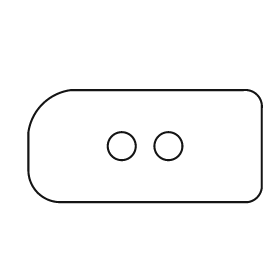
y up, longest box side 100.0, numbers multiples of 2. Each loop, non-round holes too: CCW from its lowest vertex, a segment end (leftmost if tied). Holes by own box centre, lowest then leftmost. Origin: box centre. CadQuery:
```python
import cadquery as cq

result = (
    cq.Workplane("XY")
    .moveTo(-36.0, -24.0)
    .lineTo(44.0, -24.0)
    .threePointArc((48.0, -22.0), (50.0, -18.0))
    .lineTo(50.0, 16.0)
    .threePointArc((48.0, 22.0), (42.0, 24.0))
    .lineTo(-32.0, 24.0)
    .threePointArc((-44.0, 18.0), (-50.0, 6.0))
    .lineTo(-50.0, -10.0)
    .threePointArc((-46.0, -20.0), (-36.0, -24.0))
    .close()
    .moveTo(-10.0, 0.0)
    .circle(6.0)
    .moveTo(10.0, 0.0)
    .circle(6.0)
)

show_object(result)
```